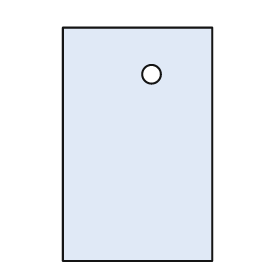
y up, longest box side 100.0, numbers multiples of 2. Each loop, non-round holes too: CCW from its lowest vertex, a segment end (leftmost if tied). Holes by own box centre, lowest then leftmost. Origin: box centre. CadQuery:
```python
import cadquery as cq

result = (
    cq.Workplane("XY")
    .moveTo(-32.0, -50.0)
    .lineTo(32.0, -50.0)
    .lineTo(32.0, 50.0)
    .lineTo(-32.0, 50.0)
    .close()
    .moveTo(6.0, 30.0)
    .circle(4.0)
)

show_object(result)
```